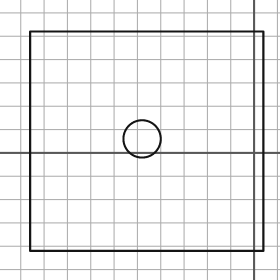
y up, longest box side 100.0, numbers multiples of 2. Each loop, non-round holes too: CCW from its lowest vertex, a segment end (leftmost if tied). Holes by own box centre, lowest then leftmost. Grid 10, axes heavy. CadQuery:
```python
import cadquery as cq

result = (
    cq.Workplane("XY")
    .moveTo(-96.0, -42.0)
    .lineTo(4.0, -42.0)
    .lineTo(4.0, 52.0)
    .lineTo(-96.0, 52.0)
    .close()
    .moveTo(-48.0, 6.0)
    .circle(8.0)
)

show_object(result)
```